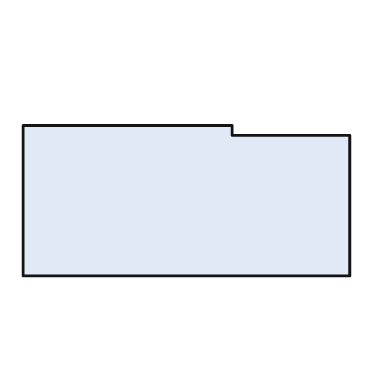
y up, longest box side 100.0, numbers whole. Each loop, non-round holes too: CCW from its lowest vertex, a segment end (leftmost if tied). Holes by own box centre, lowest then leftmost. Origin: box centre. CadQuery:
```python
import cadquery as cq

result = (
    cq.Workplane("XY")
    .moveTo(-50.0, -23.0)
    .lineTo(50.0, -23.0)
    .lineTo(50.0, 20.0)
    .lineTo(14.0, 20.0)
    .lineTo(14.0, 23.0)
    .lineTo(-50.0, 23.0)
    .close()
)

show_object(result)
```